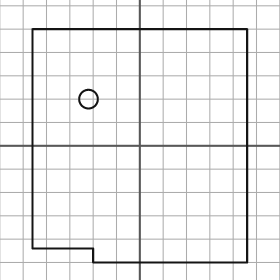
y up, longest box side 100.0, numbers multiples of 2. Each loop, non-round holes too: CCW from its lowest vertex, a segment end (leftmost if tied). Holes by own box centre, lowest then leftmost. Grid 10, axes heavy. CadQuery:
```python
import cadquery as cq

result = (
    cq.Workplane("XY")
    .moveTo(-20.0, -50.0)
    .lineTo(46.0, -50.0)
    .lineTo(46.0, 50.0)
    .lineTo(-46.0, 50.0)
    .lineTo(-46.0, -44.0)
    .lineTo(-20.0, -44.0)
    .close()
    .moveTo(-22.0, 20.0)
    .circle(4.0)
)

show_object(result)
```